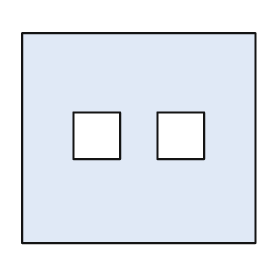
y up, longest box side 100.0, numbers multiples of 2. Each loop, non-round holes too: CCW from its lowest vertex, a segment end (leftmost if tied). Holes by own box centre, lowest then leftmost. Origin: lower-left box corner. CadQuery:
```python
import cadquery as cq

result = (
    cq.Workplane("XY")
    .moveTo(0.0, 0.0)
    .lineTo(100.0, 0.0)
    .lineTo(100.0, 90.0)
    .lineTo(0.0, 90.0)
    .close()
    .moveTo(22.0, 36.0)
    .lineTo(42.0, 36.0)
    .lineTo(42.0, 56.0)
    .lineTo(22.0, 56.0)
    .close()
    .moveTo(58.0, 36.0)
    .lineTo(78.0, 36.0)
    .lineTo(78.0, 56.0)
    .lineTo(58.0, 56.0)
    .close()
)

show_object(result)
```